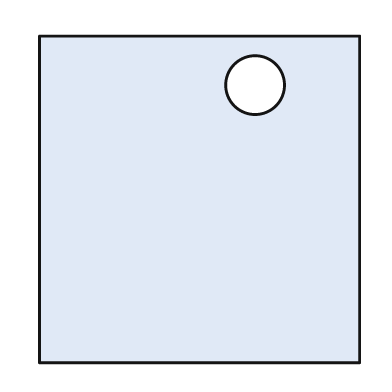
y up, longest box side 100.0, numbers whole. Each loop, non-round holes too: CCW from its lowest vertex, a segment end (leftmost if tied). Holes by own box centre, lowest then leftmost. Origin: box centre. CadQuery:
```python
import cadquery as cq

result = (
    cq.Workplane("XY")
    .moveTo(-49.0, -50.0)
    .lineTo(49.0, -50.0)
    .lineTo(49.0, 50.0)
    .lineTo(-49.0, 50.0)
    .close()
    .moveTo(17.0, 35.0)
    .circle(9.0)
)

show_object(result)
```